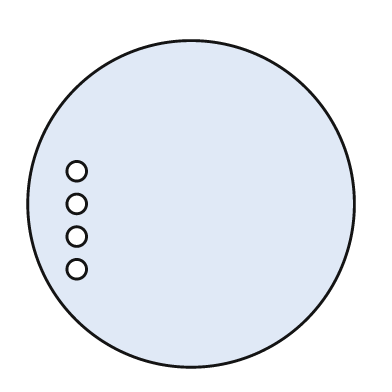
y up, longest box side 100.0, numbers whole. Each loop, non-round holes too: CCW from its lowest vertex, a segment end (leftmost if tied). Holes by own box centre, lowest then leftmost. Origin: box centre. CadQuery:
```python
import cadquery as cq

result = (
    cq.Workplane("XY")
    .moveTo(0.0, 0.0)
    .circle(50.0)
    .moveTo(-35.0, -20.0)
    .circle(3.0)
    .moveTo(-35.0, -10.0)
    .circle(3.0)
    .moveTo(-35.0, 0.0)
    .circle(3.0)
    .moveTo(-35.0, 10.0)
    .circle(3.0)
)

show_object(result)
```